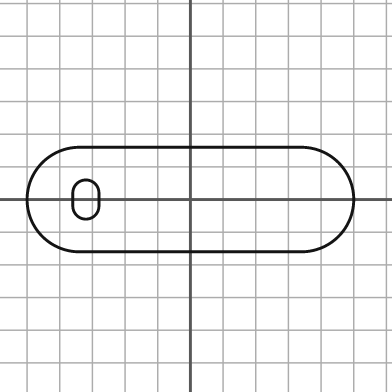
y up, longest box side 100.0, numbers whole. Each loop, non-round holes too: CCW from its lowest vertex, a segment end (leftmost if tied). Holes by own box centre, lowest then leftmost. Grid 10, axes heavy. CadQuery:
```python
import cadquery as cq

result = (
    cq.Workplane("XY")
    .moveTo(-34.0, -16.0)
    .lineTo(34.0, -16.0)
    .threePointArc((50.0, 0.0), (34.0, 16.0))
    .lineTo(-34.0, 16.0)
    .threePointArc((-50.0, 0.0), (-34.0, -16.0))
    .close()
    .moveTo(-36.0, -2.0)
    .threePointArc((-32.0, -6.0), (-28.0, -2.0))
    .lineTo(-28.0, 2.0)
    .threePointArc((-32.0, 6.0), (-36.0, 2.0))
    .close()
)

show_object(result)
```